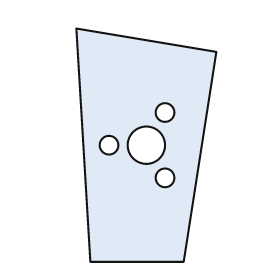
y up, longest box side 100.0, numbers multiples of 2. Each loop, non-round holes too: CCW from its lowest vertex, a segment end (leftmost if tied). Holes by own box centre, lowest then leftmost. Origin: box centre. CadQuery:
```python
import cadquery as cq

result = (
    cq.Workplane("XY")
    .moveTo(-24.0, -50.0)
    .lineTo(16.0, -50.0)
    .lineTo(30.0, 40.0)
    .lineTo(-30.0, 50.0)
    .close()
    .moveTo(8.0, -14.0)
    .circle(4.0)
    .moveTo(-16.0, 0.0)
    .circle(4.0)
    .moveTo(0.0, 0.0)
    .circle(8.0)
    .moveTo(8.0, 14.0)
    .circle(4.0)
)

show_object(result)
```